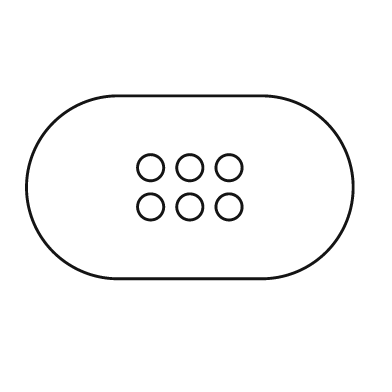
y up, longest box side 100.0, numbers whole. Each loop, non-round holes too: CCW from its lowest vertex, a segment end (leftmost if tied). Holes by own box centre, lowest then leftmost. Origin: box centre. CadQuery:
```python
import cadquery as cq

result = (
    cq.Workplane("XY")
    .moveTo(-22.0, -28.0)
    .lineTo(22.0, -28.0)
    .threePointArc((50.0, 0.0), (22.0, 28.0))
    .lineTo(-22.0, 28.0)
    .threePointArc((-50.0, 0.0), (-22.0, -28.0))
    .close()
    .moveTo(-12.0, -6.0)
    .circle(4.0)
    .moveTo(0.0, -6.0)
    .circle(4.0)
    .moveTo(12.0, -6.0)
    .circle(4.0)
    .moveTo(-12.0, 6.0)
    .circle(4.0)
    .moveTo(0.0, 6.0)
    .circle(4.0)
    .moveTo(12.0, 6.0)
    .circle(4.0)
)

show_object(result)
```